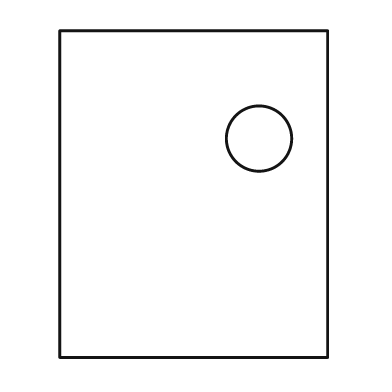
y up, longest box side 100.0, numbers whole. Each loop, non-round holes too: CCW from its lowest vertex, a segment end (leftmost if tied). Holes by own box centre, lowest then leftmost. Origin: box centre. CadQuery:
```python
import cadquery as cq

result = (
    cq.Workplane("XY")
    .moveTo(-41.0, -50.0)
    .lineTo(41.0, -50.0)
    .lineTo(41.0, 50.0)
    .lineTo(-41.0, 50.0)
    .close()
    .moveTo(20.0, 17.0)
    .circle(10.0)
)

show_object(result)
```